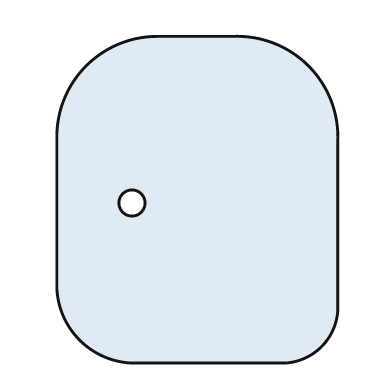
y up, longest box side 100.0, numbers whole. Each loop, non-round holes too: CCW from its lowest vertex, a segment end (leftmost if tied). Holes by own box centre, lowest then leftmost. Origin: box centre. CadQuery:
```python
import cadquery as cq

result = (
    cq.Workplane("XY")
    .moveTo(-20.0, -50.0)
    .lineTo(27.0, -50.0)
    .threePointArc((38.0, -45.0), (43.0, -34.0))
    .lineTo(43.0, 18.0)
    .threePointArc((34.0, 41.0), (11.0, 50.0))
    .lineTo(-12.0, 50.0)
    .threePointArc((-34.0, 41.0), (-43.0, 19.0))
    .lineTo(-43.0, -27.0)
    .threePointArc((-36.0, -43.0), (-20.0, -50.0))
    .close()
    .moveTo(-20.0, -1.0)
    .circle(4.0)
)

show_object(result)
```